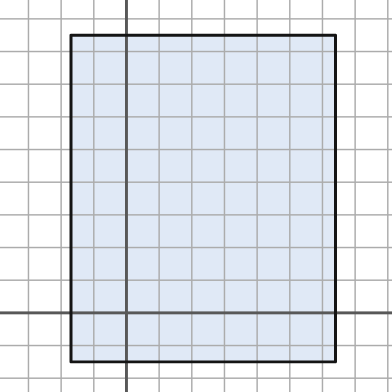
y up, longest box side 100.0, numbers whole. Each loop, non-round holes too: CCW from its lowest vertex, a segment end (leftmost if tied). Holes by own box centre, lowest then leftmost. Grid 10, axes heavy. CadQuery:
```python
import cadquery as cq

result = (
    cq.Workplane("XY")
    .moveTo(-17.0, -15.0)
    .lineTo(64.0, -15.0)
    .lineTo(64.0, 85.0)
    .lineTo(-17.0, 85.0)
    .close()
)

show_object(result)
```